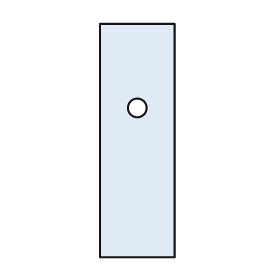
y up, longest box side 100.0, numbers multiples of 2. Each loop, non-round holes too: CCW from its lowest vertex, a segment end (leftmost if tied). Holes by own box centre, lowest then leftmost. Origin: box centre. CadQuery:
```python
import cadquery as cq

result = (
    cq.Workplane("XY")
    .moveTo(-16.0, -50.0)
    .lineTo(16.0, -50.0)
    .lineTo(16.0, 50.0)
    .lineTo(-16.0, 50.0)
    .close()
    .moveTo(0.0, 14.0)
    .circle(4.0)
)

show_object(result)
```